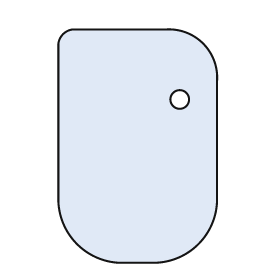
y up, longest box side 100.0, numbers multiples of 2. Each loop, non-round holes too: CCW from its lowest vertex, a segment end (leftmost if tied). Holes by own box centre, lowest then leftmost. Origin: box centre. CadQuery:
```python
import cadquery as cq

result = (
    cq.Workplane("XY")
    .moveTo(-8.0, -50.0)
    .lineTo(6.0, -50.0)
    .threePointArc((26.0, -42.0), (34.0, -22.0))
    .lineTo(34.0, 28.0)
    .threePointArc((28.0, 44.0), (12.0, 50.0))
    .lineTo(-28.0, 50.0)
    .threePointArc((-32.0, 48.0), (-34.0, 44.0))
    .lineTo(-34.0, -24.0)
    .threePointArc((-26.0, -42.0), (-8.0, -50.0))
    .close()
    .moveTo(18.0, 20.0)
    .circle(4.0)
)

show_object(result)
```